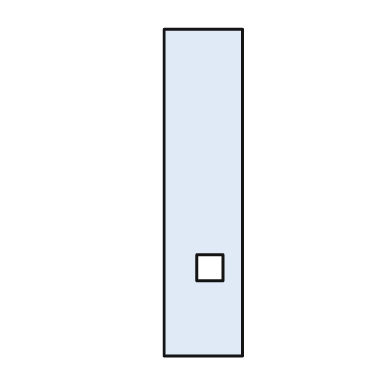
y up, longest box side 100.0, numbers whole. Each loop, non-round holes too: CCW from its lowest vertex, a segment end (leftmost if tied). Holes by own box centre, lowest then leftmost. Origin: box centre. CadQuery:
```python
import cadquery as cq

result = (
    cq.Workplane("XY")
    .moveTo(-12.0, -50.0)
    .lineTo(12.0, -50.0)
    .lineTo(12.0, 50.0)
    .lineTo(-12.0, 50.0)
    .close()
    .moveTo(-2.0, -27.0)
    .lineTo(6.0, -27.0)
    .lineTo(6.0, -19.0)
    .lineTo(-2.0, -19.0)
    .close()
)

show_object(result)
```